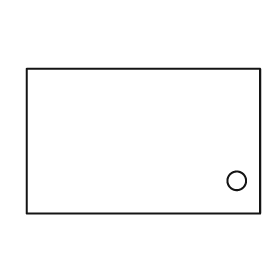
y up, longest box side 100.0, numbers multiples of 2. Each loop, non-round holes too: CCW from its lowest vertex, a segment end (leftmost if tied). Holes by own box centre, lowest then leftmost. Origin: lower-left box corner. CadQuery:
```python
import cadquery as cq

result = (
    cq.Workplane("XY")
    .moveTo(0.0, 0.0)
    .lineTo(100.0, 0.0)
    .lineTo(100.0, 62.0)
    .lineTo(0.0, 62.0)
    .close()
    .moveTo(90.0, 14.0)
    .circle(4.0)
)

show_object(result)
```